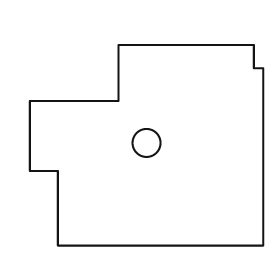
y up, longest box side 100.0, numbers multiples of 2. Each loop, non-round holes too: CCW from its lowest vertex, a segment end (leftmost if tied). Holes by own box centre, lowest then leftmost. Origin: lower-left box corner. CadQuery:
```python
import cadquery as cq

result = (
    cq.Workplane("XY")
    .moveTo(12.0, 0.0)
    .lineTo(100.0, 0.0)
    .lineTo(100.0, 76.0)
    .lineTo(96.0, 76.0)
    .lineTo(96.0, 86.0)
    .lineTo(38.0, 86.0)
    .lineTo(38.0, 62.0)
    .lineTo(0.0, 62.0)
    .lineTo(0.0, 32.0)
    .lineTo(12.0, 32.0)
    .close()
    .moveTo(50.0, 44.0)
    .circle(6.0)
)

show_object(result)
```